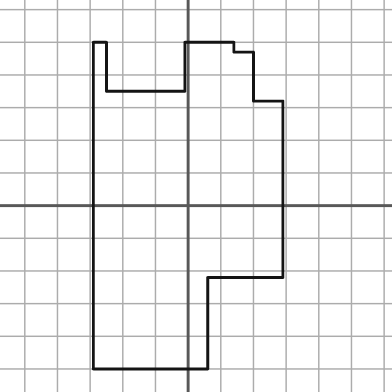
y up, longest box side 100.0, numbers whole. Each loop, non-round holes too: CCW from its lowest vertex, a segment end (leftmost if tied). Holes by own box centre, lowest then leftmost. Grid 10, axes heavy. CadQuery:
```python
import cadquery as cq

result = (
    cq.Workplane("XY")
    .moveTo(-29.0, -50.0)
    .lineTo(6.0, -50.0)
    .lineTo(6.0, -22.0)
    .lineTo(29.0, -22.0)
    .lineTo(29.0, 32.0)
    .lineTo(20.0, 32.0)
    .lineTo(20.0, 47.0)
    .lineTo(14.0, 47.0)
    .lineTo(14.0, 50.0)
    .lineTo(-1.0, 50.0)
    .lineTo(-1.0, 35.0)
    .lineTo(-25.0, 35.0)
    .lineTo(-25.0, 50.0)
    .lineTo(-29.0, 50.0)
    .close()
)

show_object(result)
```